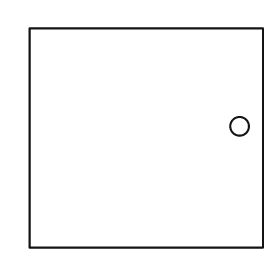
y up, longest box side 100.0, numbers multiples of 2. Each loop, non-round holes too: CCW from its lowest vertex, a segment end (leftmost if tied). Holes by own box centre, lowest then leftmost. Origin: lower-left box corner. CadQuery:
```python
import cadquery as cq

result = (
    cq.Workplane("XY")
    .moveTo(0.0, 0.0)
    .lineTo(100.0, 0.0)
    .lineTo(100.0, 94.0)
    .lineTo(0.0, 94.0)
    .close()
    .moveTo(90.0, 52.0)
    .circle(4.0)
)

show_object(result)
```